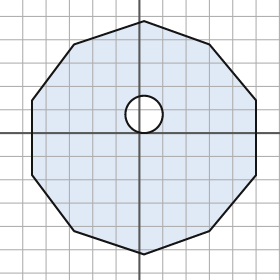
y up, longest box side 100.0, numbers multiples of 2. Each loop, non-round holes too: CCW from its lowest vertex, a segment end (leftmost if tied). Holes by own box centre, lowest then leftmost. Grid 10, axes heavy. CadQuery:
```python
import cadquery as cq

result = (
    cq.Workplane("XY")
    .moveTo(2.0, -52.0)
    .lineTo(30.0, -42.0)
    .lineTo(50.0, -18.0)
    .lineTo(50.0, 14.0)
    .lineTo(30.0, 38.0)
    .lineTo(2.0, 48.0)
    .lineTo(-28.0, 38.0)
    .lineTo(-46.0, 14.0)
    .lineTo(-46.0, -18.0)
    .lineTo(-28.0, -42.0)
    .close()
    .moveTo(2.0, 8.0)
    .circle(8.0)
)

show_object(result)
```